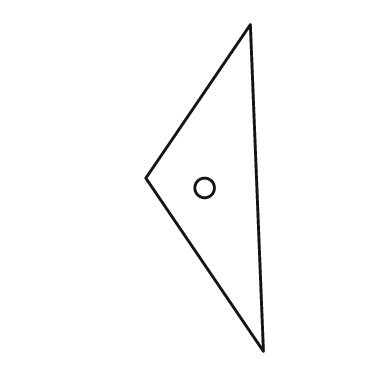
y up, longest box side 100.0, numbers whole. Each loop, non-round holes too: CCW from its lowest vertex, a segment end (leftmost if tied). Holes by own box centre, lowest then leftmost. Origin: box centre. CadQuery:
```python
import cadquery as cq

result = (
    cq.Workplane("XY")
    .moveTo(18.0, -50.0)
    .lineTo(14.0, 50.0)
    .lineTo(-18.0, 3.0)
    .close()
    .moveTo(0.0, 0.0)
    .circle(3.0)
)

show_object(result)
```